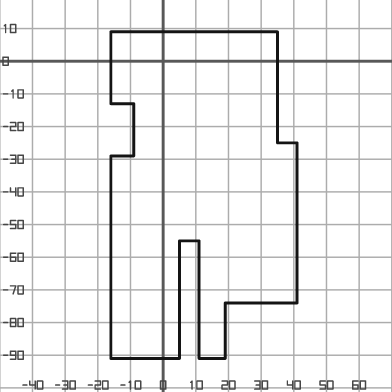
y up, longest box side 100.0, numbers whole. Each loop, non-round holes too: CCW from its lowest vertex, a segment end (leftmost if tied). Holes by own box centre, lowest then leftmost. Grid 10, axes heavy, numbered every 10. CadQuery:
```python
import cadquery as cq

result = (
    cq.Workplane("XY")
    .moveTo(-16.0, -91.0)
    .lineTo(5.0, -91.0)
    .lineTo(5.0, -55.0)
    .lineTo(11.0, -55.0)
    .lineTo(11.0, -91.0)
    .lineTo(19.0, -91.0)
    .lineTo(19.0, -74.0)
    .lineTo(41.0, -74.0)
    .lineTo(41.0, -25.0)
    .lineTo(35.0, -25.0)
    .lineTo(35.0, 9.0)
    .lineTo(-16.0, 9.0)
    .lineTo(-16.0, -13.0)
    .lineTo(-9.0, -13.0)
    .lineTo(-9.0, -29.0)
    .lineTo(-16.0, -29.0)
    .close()
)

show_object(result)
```